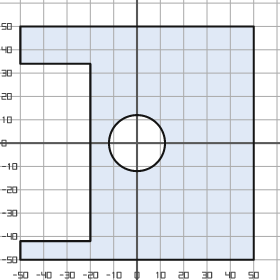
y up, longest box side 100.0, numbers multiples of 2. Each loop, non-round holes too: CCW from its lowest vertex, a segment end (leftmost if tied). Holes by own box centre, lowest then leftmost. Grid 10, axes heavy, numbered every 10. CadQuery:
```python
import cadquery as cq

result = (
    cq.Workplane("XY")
    .moveTo(-50.0, -50.0)
    .lineTo(50.0, -50.0)
    .lineTo(50.0, 50.0)
    .lineTo(-50.0, 50.0)
    .lineTo(-50.0, 34.0)
    .lineTo(-20.0, 34.0)
    .lineTo(-20.0, -42.0)
    .lineTo(-50.0, -42.0)
    .close()
    .moveTo(0.0, 0.0)
    .circle(12.0)
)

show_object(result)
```